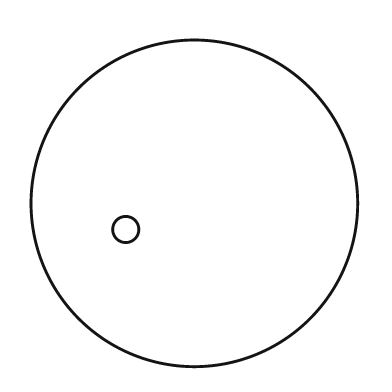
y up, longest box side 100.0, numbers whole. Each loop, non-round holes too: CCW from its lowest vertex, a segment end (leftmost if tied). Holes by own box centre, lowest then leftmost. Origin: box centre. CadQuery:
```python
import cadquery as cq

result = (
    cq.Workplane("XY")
    .moveTo(0.0, 0.0)
    .circle(50.0)
    .moveTo(-21.0, -8.0)
    .circle(4.0)
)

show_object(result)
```